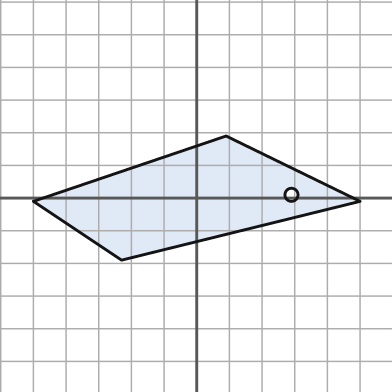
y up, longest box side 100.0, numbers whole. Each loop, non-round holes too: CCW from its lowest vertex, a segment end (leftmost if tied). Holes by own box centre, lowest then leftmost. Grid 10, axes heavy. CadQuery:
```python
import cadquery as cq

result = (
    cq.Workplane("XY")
    .moveTo(-23.0, -19.0)
    .lineTo(50.0, -1.0)
    .lineTo(9.0, 19.0)
    .lineTo(-50.0, -1.0)
    .close()
    .moveTo(29.0, 1.0)
    .circle(2.0)
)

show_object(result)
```